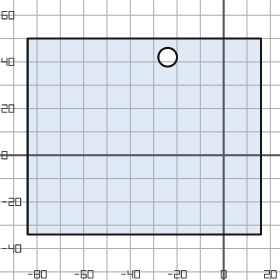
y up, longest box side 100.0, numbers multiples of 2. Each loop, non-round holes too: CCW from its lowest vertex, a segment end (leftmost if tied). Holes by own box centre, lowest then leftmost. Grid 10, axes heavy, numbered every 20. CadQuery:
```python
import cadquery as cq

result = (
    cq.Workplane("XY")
    .moveTo(-84.0, -34.0)
    .lineTo(16.0, -34.0)
    .lineTo(16.0, 50.0)
    .lineTo(-84.0, 50.0)
    .close()
    .moveTo(-24.0, 42.0)
    .circle(4.0)
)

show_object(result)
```